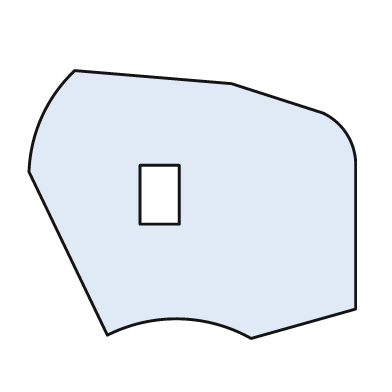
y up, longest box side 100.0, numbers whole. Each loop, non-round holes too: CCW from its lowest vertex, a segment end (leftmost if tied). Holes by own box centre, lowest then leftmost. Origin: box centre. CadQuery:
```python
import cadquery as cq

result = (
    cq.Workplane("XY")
    .moveTo(18.0, -41.0)
    .lineTo(50.0, -32.0)
    .lineTo(50.0, 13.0)
    .threePointArc((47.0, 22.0), (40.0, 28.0))
    .lineTo(12.0, 37.0)
    .lineTo(-36.0, 41.0)
    .threePointArc((-46.0, 27.0), (-50.0, 10.0))
    .lineTo(-26.0, -40.0)
    .threePointArc((-4.0, -35.0), (18.0, -41.0))
    .close()
    .moveTo(-16.0, -6.0)
    .lineTo(-4.0, -6.0)
    .lineTo(-4.0, 12.0)
    .lineTo(-16.0, 12.0)
    .close()
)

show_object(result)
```